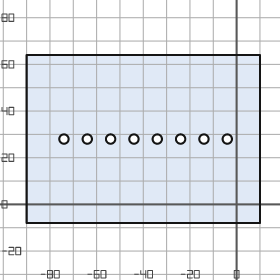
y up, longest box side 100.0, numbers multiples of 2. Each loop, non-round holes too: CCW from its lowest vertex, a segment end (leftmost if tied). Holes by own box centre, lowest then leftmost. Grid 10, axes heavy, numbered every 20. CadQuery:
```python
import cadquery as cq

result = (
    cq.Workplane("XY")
    .moveTo(-90.0, -8.0)
    .lineTo(10.0, -8.0)
    .lineTo(10.0, 64.0)
    .lineTo(-90.0, 64.0)
    .close()
    .moveTo(-74.0, 28.0)
    .circle(2.0)
    .moveTo(-64.0, 28.0)
    .circle(2.0)
    .moveTo(-54.0, 28.0)
    .circle(2.0)
    .moveTo(-44.0, 28.0)
    .circle(2.0)
    .moveTo(-34.0, 28.0)
    .circle(2.0)
    .moveTo(-24.0, 28.0)
    .circle(2.0)
    .moveTo(-14.0, 28.0)
    .circle(2.0)
    .moveTo(-4.0, 28.0)
    .circle(2.0)
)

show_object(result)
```